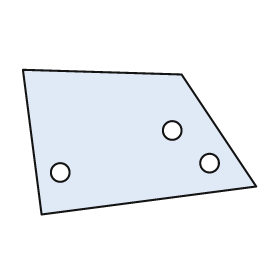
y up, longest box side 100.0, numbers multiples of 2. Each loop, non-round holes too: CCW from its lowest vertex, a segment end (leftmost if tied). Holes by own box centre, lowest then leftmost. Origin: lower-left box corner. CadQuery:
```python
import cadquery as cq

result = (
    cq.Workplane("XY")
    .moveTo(8.0, 0.0)
    .lineTo(100.0, 12.0)
    .lineTo(68.0, 60.0)
    .lineTo(0.0, 62.0)
    .close()
    .moveTo(16.0, 18.0)
    .circle(4.0)
    .moveTo(80.0, 22.0)
    .circle(4.0)
    .moveTo(64.0, 36.0)
    .circle(4.0)
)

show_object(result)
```